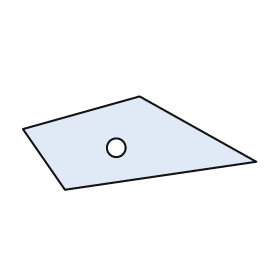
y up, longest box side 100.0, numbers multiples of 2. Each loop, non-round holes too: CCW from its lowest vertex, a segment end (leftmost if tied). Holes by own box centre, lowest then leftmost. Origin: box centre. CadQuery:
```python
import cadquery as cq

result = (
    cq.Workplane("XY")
    .moveTo(-32.0, -20.0)
    .lineTo(50.0, -8.0)
    .lineTo(0.0, 20.0)
    .lineTo(-50.0, 6.0)
    .close()
    .moveTo(-10.0, -2.0)
    .circle(4.0)
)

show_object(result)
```